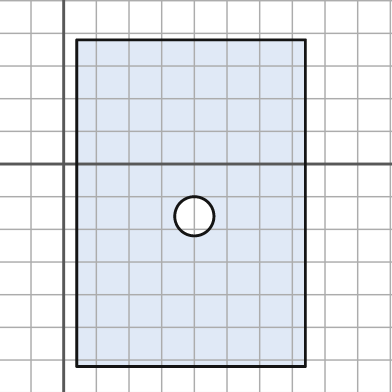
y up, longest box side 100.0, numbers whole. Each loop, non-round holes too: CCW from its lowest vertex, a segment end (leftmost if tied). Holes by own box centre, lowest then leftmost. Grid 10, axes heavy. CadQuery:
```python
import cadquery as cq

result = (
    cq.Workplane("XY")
    .moveTo(4.0, -62.0)
    .lineTo(74.0, -62.0)
    .lineTo(74.0, 38.0)
    .lineTo(4.0, 38.0)
    .close()
    .moveTo(40.0, -16.0)
    .circle(6.0)
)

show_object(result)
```